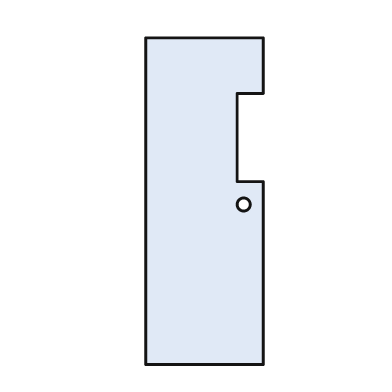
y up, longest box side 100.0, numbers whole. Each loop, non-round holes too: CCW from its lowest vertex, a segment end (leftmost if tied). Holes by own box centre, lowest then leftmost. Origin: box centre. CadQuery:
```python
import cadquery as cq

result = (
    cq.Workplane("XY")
    .moveTo(-18.0, -50.0)
    .lineTo(18.0, -50.0)
    .lineTo(18.0, 6.0)
    .lineTo(10.0, 6.0)
    .lineTo(10.0, 33.0)
    .lineTo(18.0, 33.0)
    .lineTo(18.0, 50.0)
    .lineTo(-18.0, 50.0)
    .close()
    .moveTo(12.0, -1.0)
    .circle(2.0)
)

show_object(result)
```